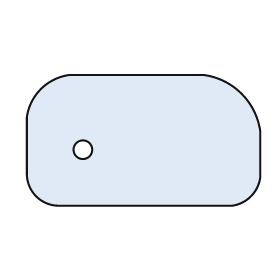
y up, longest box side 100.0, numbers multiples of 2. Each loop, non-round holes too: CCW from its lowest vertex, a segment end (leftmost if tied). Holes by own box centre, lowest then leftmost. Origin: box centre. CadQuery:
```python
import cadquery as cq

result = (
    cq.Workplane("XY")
    .moveTo(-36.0, -28.0)
    .lineTo(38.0, -28.0)
    .threePointArc((46.0, -24.0), (50.0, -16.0))
    .lineTo(50.0, 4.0)
    .threePointArc((42.0, 20.0), (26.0, 28.0))
    .lineTo(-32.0, 28.0)
    .threePointArc((-44.0, 22.0), (-50.0, 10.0))
    .lineTo(-50.0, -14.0)
    .threePointArc((-46.0, -24.0), (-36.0, -28.0))
    .close()
    .moveTo(-26.0, -4.0)
    .circle(4.0)
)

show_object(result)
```